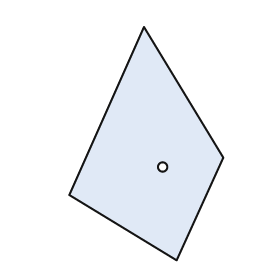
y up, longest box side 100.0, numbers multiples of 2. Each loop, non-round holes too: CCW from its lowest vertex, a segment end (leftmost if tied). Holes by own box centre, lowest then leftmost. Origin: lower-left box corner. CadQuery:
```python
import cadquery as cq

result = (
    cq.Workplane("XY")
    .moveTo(46.0, 0.0)
    .lineTo(66.0, 44.0)
    .lineTo(32.0, 100.0)
    .lineTo(0.0, 28.0)
    .close()
    .moveTo(40.0, 40.0)
    .circle(2.0)
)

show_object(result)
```